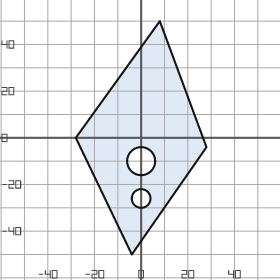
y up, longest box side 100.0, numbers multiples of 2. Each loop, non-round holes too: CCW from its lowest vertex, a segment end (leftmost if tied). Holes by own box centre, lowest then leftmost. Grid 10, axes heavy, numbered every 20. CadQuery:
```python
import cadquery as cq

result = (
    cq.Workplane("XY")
    .moveTo(-4.0, -50.0)
    .lineTo(28.0, -4.0)
    .lineTo(8.0, 50.0)
    .lineTo(-28.0, 0.0)
    .close()
    .moveTo(0.0, -26.0)
    .circle(4.0)
    .moveTo(0.0, -10.0)
    .circle(6.0)
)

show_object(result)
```